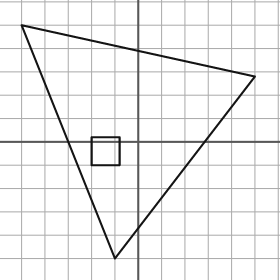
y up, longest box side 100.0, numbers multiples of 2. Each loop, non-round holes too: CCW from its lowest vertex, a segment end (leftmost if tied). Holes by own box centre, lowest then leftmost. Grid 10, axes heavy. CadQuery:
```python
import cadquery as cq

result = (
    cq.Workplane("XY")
    .moveTo(-10.0, -50.0)
    .lineTo(50.0, 28.0)
    .lineTo(-50.0, 50.0)
    .close()
    .moveTo(-20.0, -10.0)
    .lineTo(-8.0, -10.0)
    .lineTo(-8.0, 2.0)
    .lineTo(-20.0, 2.0)
    .close()
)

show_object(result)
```